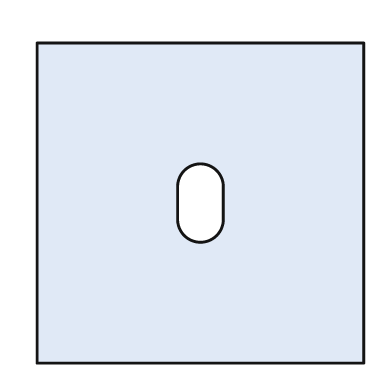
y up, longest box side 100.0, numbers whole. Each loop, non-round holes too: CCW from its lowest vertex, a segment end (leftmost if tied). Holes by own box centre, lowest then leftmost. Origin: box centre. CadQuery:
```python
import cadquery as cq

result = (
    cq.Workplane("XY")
    .moveTo(-50.0, -49.0)
    .lineTo(50.0, -49.0)
    .lineTo(50.0, 49.0)
    .lineTo(-50.0, 49.0)
    .close()
    .moveTo(-7.0, -5.0)
    .threePointArc((0.0, -12.0), (7.0, -5.0))
    .lineTo(7.0, 5.0)
    .threePointArc((0.0, 12.0), (-7.0, 5.0))
    .close()
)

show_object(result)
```